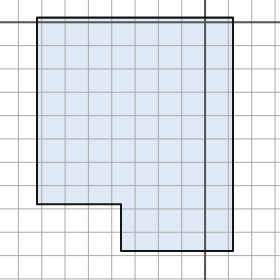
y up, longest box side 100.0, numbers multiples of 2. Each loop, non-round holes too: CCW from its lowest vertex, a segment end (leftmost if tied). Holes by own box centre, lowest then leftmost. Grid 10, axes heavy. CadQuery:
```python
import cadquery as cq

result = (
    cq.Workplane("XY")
    .moveTo(-36.0, -98.0)
    .lineTo(12.0, -98.0)
    .lineTo(12.0, 2.0)
    .lineTo(-72.0, 2.0)
    .lineTo(-72.0, -78.0)
    .lineTo(-36.0, -78.0)
    .close()
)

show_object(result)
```